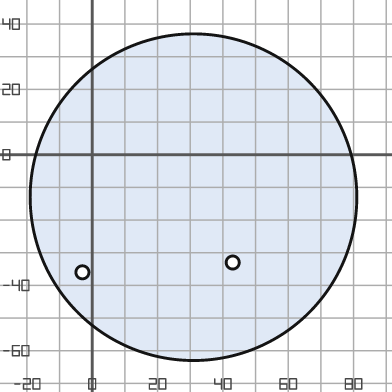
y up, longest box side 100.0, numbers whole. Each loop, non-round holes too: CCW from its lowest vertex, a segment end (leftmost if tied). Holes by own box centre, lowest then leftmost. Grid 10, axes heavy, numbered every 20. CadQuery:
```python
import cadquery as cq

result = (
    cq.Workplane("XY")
    .moveTo(31.0, -13.0)
    .circle(50.0)
    .moveTo(-3.0, -36.0)
    .circle(2.0)
    .moveTo(43.0, -33.0)
    .circle(2.0)
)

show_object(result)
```